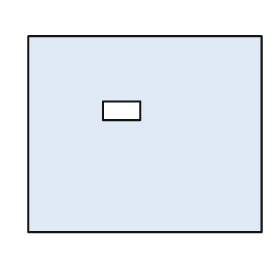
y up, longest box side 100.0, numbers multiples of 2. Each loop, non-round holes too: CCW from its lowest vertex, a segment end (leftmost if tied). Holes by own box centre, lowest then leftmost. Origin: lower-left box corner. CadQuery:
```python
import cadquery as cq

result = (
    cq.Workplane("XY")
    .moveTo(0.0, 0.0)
    .lineTo(100.0, 0.0)
    .lineTo(100.0, 84.0)
    .lineTo(0.0, 84.0)
    .close()
    .moveTo(32.0, 48.0)
    .lineTo(48.0, 48.0)
    .lineTo(48.0, 56.0)
    .lineTo(32.0, 56.0)
    .close()
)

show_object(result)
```